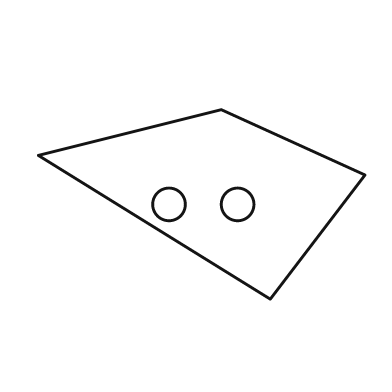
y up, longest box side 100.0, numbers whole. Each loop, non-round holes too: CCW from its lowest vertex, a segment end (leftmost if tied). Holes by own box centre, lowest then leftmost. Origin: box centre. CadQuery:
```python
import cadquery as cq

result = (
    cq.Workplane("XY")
    .moveTo(21.0, -29.0)
    .lineTo(50.0, 9.0)
    .lineTo(6.0, 29.0)
    .lineTo(-50.0, 15.0)
    .close()
    .moveTo(-10.0, 0.0)
    .circle(5.0)
    .moveTo(11.0, 0.0)
    .circle(5.0)
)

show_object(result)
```